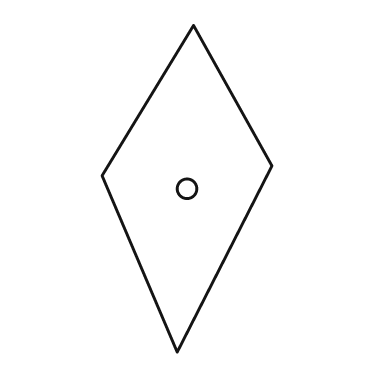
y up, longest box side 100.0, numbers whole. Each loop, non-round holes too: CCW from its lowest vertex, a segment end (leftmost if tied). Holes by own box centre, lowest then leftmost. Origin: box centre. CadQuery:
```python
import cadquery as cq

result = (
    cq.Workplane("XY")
    .moveTo(-3.0, -50.0)
    .lineTo(26.0, 7.0)
    .lineTo(2.0, 50.0)
    .lineTo(-26.0, 4.0)
    .close()
    .moveTo(0.0, 0.0)
    .circle(3.0)
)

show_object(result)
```